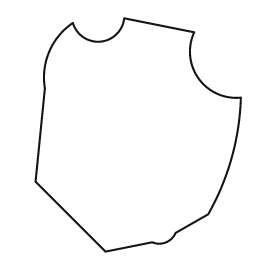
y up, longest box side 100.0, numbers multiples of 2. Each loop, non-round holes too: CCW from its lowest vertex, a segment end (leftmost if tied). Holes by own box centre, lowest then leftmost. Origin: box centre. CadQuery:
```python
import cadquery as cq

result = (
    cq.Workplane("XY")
    .moveTo(-14.0, -50.0)
    .lineTo(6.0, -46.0)
    .threePointArc((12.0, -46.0), (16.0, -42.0))
    .lineTo(30.0, -34.0)
    .threePointArc((40.0, -10.0), (44.0, 16.0))
    .threePointArc((26.0, 24.0), (24.0, 44.0))
    .lineTo(-6.0, 50.0)
    .threePointArc((-16.0, 40.0), (-28.0, 48.0))
    .threePointArc((-38.0, 36.0), (-40.0, 20.0))
    .lineTo(-44.0, -20.0)
    .close()
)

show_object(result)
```